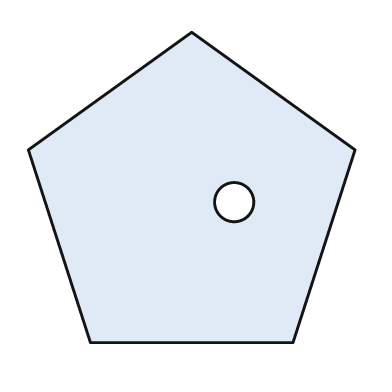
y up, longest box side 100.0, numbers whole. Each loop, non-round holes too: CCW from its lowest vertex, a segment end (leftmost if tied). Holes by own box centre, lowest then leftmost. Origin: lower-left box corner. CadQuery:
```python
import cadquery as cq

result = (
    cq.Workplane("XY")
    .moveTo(19.0, 0.0)
    .lineTo(81.0, 0.0)
    .lineTo(100.0, 59.0)
    .lineTo(50.0, 95.0)
    .lineTo(0.0, 59.0)
    .close()
    .moveTo(63.0, 43.0)
    .circle(6.0)
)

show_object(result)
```